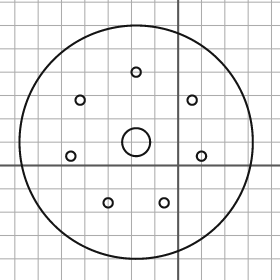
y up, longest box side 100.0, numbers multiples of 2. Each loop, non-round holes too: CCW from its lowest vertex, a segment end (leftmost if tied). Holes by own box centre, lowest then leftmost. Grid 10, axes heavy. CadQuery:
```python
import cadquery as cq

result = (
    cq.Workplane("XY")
    .moveTo(-18.0, 10.0)
    .circle(50.0)
    .moveTo(-30.0, -16.0)
    .circle(2.0)
    .moveTo(-6.0, -16.0)
    .circle(2.0)
    .moveTo(-46.0, 4.0)
    .circle(2.0)
    .moveTo(10.0, 4.0)
    .circle(2.0)
    .moveTo(-18.0, 10.0)
    .circle(6.0)
    .moveTo(-42.0, 28.0)
    .circle(2.0)
    .moveTo(6.0, 28.0)
    .circle(2.0)
    .moveTo(-18.0, 40.0)
    .circle(2.0)
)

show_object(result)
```